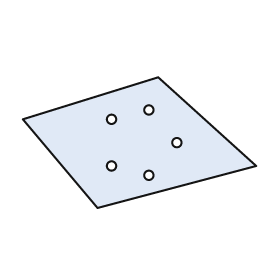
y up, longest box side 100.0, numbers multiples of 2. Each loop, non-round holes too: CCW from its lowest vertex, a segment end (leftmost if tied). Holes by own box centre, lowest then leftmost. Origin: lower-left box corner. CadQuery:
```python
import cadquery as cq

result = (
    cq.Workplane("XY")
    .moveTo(32.0, 0.0)
    .lineTo(100.0, 18.0)
    .lineTo(58.0, 56.0)
    .lineTo(0.0, 38.0)
    .close()
    .moveTo(54.0, 14.0)
    .circle(2.0)
    .moveTo(38.0, 18.0)
    .circle(2.0)
    .moveTo(66.0, 28.0)
    .circle(2.0)
    .moveTo(38.0, 38.0)
    .circle(2.0)
    .moveTo(54.0, 42.0)
    .circle(2.0)
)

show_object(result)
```